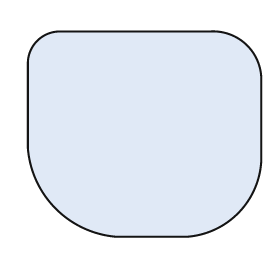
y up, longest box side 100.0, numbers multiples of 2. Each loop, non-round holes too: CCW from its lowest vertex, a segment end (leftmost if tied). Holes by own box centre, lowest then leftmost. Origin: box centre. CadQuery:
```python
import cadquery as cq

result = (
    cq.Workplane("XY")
    .moveTo(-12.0, -44.0)
    .lineTo(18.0, -44.0)
    .threePointArc((40.0, -34.0), (50.0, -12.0))
    .lineTo(50.0, 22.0)
    .threePointArc((44.0, 38.0), (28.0, 44.0))
    .lineTo(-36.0, 44.0)
    .threePointArc((-46.0, 40.0), (-50.0, 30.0))
    .lineTo(-50.0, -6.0)
    .threePointArc((-38.0, -32.0), (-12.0, -44.0))
    .close()
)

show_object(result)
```